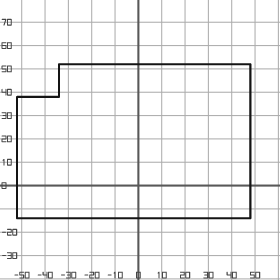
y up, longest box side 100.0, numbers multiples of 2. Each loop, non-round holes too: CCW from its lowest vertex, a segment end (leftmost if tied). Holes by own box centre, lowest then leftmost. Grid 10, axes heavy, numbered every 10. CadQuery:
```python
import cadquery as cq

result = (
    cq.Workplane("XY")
    .moveTo(-52.0, -14.0)
    .lineTo(48.0, -14.0)
    .lineTo(48.0, 52.0)
    .lineTo(-34.0, 52.0)
    .lineTo(-34.0, 38.0)
    .lineTo(-52.0, 38.0)
    .close()
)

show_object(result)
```